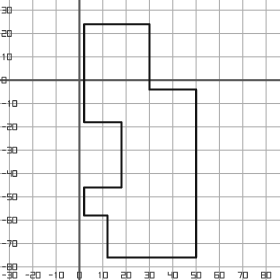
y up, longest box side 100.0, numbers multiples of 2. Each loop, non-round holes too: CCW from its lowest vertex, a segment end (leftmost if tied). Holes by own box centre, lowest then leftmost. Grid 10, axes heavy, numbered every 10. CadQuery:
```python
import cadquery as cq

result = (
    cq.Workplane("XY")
    .moveTo(12.0, -76.0)
    .lineTo(50.0, -76.0)
    .lineTo(50.0, -4.0)
    .lineTo(30.0, -4.0)
    .lineTo(30.0, 24.0)
    .lineTo(2.0, 24.0)
    .lineTo(2.0, -18.0)
    .lineTo(18.0, -18.0)
    .lineTo(18.0, -46.0)
    .lineTo(2.0, -46.0)
    .lineTo(2.0, -58.0)
    .lineTo(12.0, -58.0)
    .close()
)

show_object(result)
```